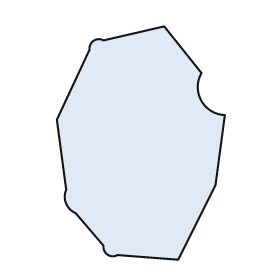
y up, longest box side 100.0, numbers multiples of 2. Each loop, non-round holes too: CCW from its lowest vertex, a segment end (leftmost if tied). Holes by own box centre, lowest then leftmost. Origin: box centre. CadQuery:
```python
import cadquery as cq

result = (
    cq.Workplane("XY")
    .moveTo(16.0, -50.0)
    .lineTo(32.0, -18.0)
    .lineTo(36.0, 12.0)
    .threePointArc((26.0, 18.0), (26.0, 30.0))
    .lineTo(10.0, 50.0)
    .lineTo(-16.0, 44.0)
    .threePointArc((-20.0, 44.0), (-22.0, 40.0))
    .lineTo(-36.0, 10.0)
    .lineTo(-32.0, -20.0)
    .threePointArc((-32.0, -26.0), (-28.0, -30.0))
    .lineTo(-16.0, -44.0)
    .threePointArc((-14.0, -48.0), (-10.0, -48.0))
    .close()
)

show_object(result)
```